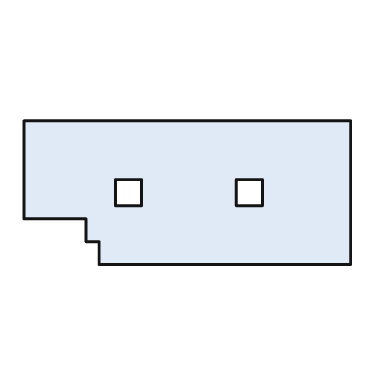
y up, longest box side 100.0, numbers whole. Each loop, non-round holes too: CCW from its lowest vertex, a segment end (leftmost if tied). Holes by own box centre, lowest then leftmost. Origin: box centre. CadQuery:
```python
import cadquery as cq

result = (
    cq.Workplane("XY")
    .moveTo(-27.0, -22.0)
    .lineTo(50.0, -22.0)
    .lineTo(50.0, 22.0)
    .lineTo(-50.0, 22.0)
    .lineTo(-50.0, -8.0)
    .lineTo(-31.0, -8.0)
    .lineTo(-31.0, -15.0)
    .lineTo(-27.0, -15.0)
    .close()
    .moveTo(-22.0, -4.0)
    .lineTo(-14.0, -4.0)
    .lineTo(-14.0, 4.0)
    .lineTo(-22.0, 4.0)
    .close()
    .moveTo(15.0, -4.0)
    .lineTo(23.0, -4.0)
    .lineTo(23.0, 4.0)
    .lineTo(15.0, 4.0)
    .close()
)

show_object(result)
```